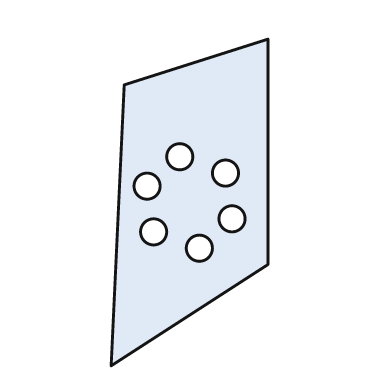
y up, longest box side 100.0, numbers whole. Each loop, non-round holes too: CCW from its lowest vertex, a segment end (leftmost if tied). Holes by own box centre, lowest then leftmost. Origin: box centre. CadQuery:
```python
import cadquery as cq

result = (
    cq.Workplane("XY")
    .moveTo(-24.0, -50.0)
    .lineTo(24.0, -19.0)
    .lineTo(24.0, 50.0)
    .lineTo(-20.0, 36.0)
    .close()
    .moveTo(3.0, -14.0)
    .circle(4.0)
    .moveTo(-11.0, -9.0)
    .circle(4.0)
    .moveTo(13.0, -5.0)
    .circle(4.0)
    .moveTo(-13.0, 5.0)
    .circle(4.0)
    .moveTo(11.0, 9.0)
    .circle(4.0)
    .moveTo(-3.0, 14.0)
    .circle(4.0)
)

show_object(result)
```